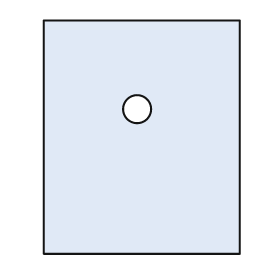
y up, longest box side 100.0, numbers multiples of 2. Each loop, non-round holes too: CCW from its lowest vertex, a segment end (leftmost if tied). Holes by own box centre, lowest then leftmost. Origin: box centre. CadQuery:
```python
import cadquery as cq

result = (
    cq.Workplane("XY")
    .moveTo(-42.0, -50.0)
    .lineTo(42.0, -50.0)
    .lineTo(42.0, 50.0)
    .lineTo(-42.0, 50.0)
    .close()
    .moveTo(-2.0, 12.0)
    .circle(6.0)
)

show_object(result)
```